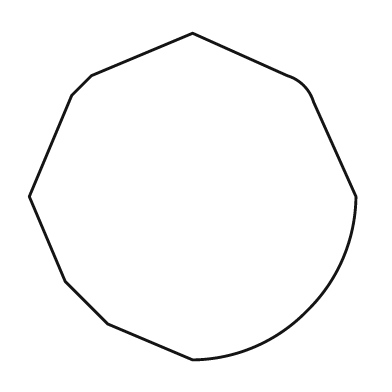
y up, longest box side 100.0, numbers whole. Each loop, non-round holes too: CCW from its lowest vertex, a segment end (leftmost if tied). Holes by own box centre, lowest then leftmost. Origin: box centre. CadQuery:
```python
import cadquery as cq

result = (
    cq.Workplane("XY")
    .moveTo(0.0, -50.0)
    .threePointArc((19.0, -46.0), (35.0, -35.0))
    .threePointArc((46.0, -19.0), (50.0, 0.0))
    .lineTo(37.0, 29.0)
    .threePointArc((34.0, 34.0), (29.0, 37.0))
    .lineTo(0.0, 50.0)
    .lineTo(-31.0, 37.0)
    .lineTo(-37.0, 31.0)
    .lineTo(-50.0, 0.0)
    .lineTo(-39.0, -26.0)
    .lineTo(-26.0, -39.0)
    .close()
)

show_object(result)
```